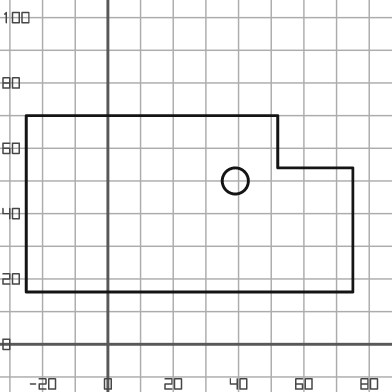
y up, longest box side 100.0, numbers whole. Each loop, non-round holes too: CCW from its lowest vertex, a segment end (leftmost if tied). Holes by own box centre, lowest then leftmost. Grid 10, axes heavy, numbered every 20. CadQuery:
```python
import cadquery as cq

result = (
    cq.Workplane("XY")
    .moveTo(-25.0, 16.0)
    .lineTo(75.0, 16.0)
    .lineTo(75.0, 54.0)
    .lineTo(52.0, 54.0)
    .lineTo(52.0, 70.0)
    .lineTo(-25.0, 70.0)
    .close()
    .moveTo(39.0, 50.0)
    .circle(4.0)
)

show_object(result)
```